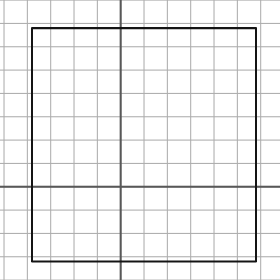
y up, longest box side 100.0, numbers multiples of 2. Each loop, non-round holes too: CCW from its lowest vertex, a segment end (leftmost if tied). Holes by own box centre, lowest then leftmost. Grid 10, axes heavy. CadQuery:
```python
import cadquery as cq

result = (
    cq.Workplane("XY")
    .moveTo(-38.0, -32.0)
    .lineTo(58.0, -32.0)
    .lineTo(58.0, 68.0)
    .lineTo(-38.0, 68.0)
    .close()
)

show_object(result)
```